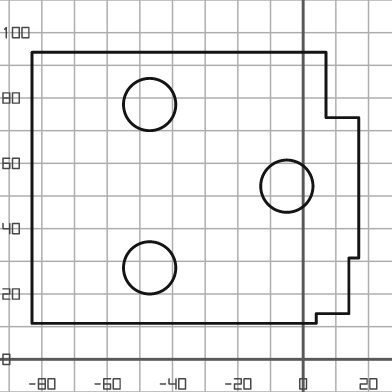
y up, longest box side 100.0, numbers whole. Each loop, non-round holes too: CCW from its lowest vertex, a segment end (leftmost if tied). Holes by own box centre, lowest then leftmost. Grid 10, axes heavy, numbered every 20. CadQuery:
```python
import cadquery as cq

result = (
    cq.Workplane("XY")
    .moveTo(-83.0, 11.0)
    .lineTo(4.0, 11.0)
    .lineTo(4.0, 14.0)
    .lineTo(14.0, 14.0)
    .lineTo(14.0, 31.0)
    .lineTo(17.0, 31.0)
    .lineTo(17.0, 74.0)
    .lineTo(7.0, 74.0)
    .lineTo(7.0, 94.0)
    .lineTo(-83.0, 94.0)
    .close()
    .moveTo(-47.0, 28.0)
    .circle(8.0)
    .moveTo(-5.0, 53.0)
    .circle(8.0)
    .moveTo(-47.0, 78.0)
    .circle(8.0)
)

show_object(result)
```